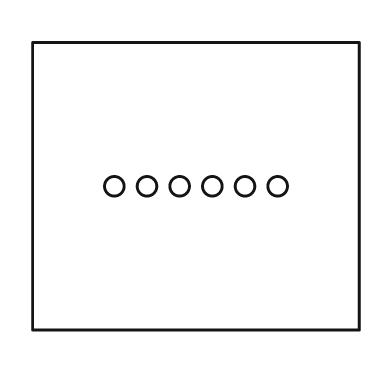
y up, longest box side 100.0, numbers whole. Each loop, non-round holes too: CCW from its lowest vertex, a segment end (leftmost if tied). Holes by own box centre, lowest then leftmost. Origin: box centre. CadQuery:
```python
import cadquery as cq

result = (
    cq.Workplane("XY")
    .moveTo(-50.0, -44.0)
    .lineTo(50.0, -44.0)
    .lineTo(50.0, 44.0)
    .lineTo(-50.0, 44.0)
    .close()
    .moveTo(-25.0, 0.0)
    .circle(3.0)
    .moveTo(-15.0, 0.0)
    .circle(3.0)
    .moveTo(-5.0, 0.0)
    .circle(3.0)
    .moveTo(5.0, 0.0)
    .circle(3.0)
    .moveTo(15.0, 0.0)
    .circle(3.0)
    .moveTo(25.0, 0.0)
    .circle(3.0)
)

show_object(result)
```